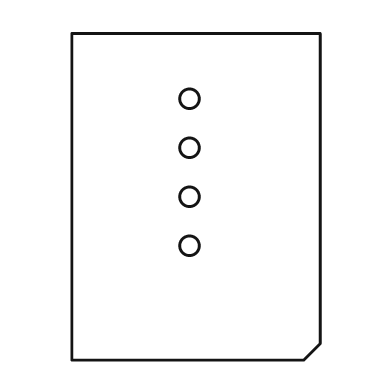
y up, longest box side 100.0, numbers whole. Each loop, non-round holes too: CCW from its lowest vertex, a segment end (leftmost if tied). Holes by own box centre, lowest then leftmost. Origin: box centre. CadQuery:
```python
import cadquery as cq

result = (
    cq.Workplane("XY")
    .moveTo(-38.0, -50.0)
    .lineTo(33.0, -50.0)
    .lineTo(38.0, -45.0)
    .lineTo(38.0, 50.0)
    .lineTo(-38.0, 50.0)
    .close()
    .moveTo(-2.0, -15.0)
    .circle(3.0)
    .moveTo(-2.0, 0.0)
    .circle(3.0)
    .moveTo(-2.0, 15.0)
    .circle(3.0)
    .moveTo(-2.0, 30.0)
    .circle(3.0)
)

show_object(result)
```